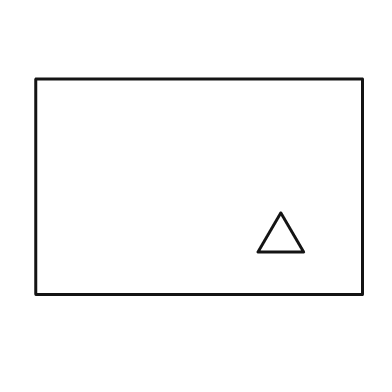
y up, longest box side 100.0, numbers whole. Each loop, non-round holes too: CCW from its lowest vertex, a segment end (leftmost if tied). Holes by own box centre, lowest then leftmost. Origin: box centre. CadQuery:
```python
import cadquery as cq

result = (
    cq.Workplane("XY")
    .moveTo(-50.0, -33.0)
    .lineTo(50.0, -33.0)
    .lineTo(50.0, 33.0)
    .lineTo(-50.0, 33.0)
    .close()
    .moveTo(18.0, -20.0)
    .lineTo(32.0, -20.0)
    .lineTo(25.0, -8.0)
    .close()
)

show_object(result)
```